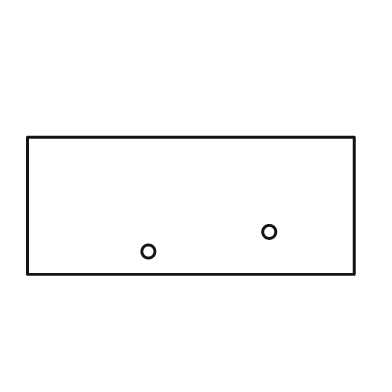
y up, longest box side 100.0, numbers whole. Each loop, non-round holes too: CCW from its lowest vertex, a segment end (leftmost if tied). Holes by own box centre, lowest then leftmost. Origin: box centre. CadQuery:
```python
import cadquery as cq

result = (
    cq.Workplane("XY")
    .moveTo(-50.0, -21.0)
    .lineTo(50.0, -21.0)
    .lineTo(50.0, 21.0)
    .lineTo(-50.0, 21.0)
    .close()
    .moveTo(-13.0, -14.0)
    .circle(2.0)
    .moveTo(24.0, -8.0)
    .circle(2.0)
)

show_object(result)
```